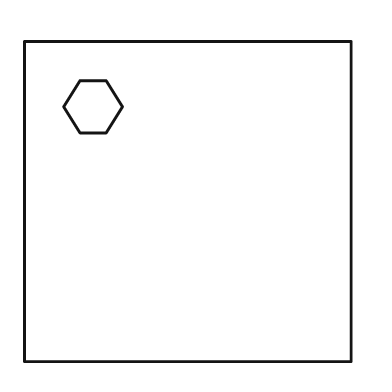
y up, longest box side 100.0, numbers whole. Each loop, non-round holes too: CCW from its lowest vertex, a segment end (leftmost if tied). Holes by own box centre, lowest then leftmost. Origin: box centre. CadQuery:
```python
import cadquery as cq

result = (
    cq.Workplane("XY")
    .moveTo(-50.0, -49.0)
    .lineTo(50.0, -49.0)
    .lineTo(50.0, 49.0)
    .lineTo(-50.0, 49.0)
    .close()
    .moveTo(-33.0, 21.0)
    .lineTo(-25.0, 21.0)
    .lineTo(-20.0, 29.0)
    .lineTo(-25.0, 37.0)
    .lineTo(-33.0, 37.0)
    .lineTo(-38.0, 29.0)
    .close()
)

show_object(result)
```